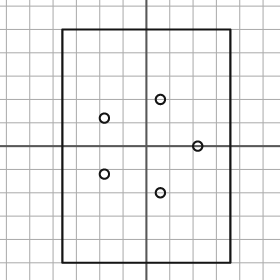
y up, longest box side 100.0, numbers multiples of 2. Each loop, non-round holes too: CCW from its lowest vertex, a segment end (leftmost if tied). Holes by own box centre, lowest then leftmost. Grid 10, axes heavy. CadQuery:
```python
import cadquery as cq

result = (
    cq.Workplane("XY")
    .moveTo(-36.0, -50.0)
    .lineTo(36.0, -50.0)
    .lineTo(36.0, 50.0)
    .lineTo(-36.0, 50.0)
    .close()
    .moveTo(6.0, -20.0)
    .circle(2.0)
    .moveTo(-18.0, -12.0)
    .circle(2.0)
    .moveTo(22.0, 0.0)
    .circle(2.0)
    .moveTo(-18.0, 12.0)
    .circle(2.0)
    .moveTo(6.0, 20.0)
    .circle(2.0)
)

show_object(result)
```